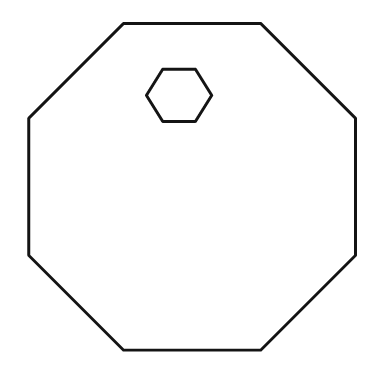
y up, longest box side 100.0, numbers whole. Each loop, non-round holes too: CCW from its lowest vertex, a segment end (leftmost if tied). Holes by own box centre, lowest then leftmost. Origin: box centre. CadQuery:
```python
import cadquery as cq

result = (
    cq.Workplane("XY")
    .moveTo(-21.0, -50.0)
    .lineTo(21.0, -50.0)
    .lineTo(50.0, -21.0)
    .lineTo(50.0, 21.0)
    .lineTo(21.0, 50.0)
    .lineTo(-21.0, 50.0)
    .lineTo(-50.0, 21.0)
    .lineTo(-50.0, -21.0)
    .close()
    .moveTo(-9.0, 20.0)
    .lineTo(1.0, 20.0)
    .lineTo(6.0, 28.0)
    .lineTo(1.0, 36.0)
    .lineTo(-9.0, 36.0)
    .lineTo(-14.0, 28.0)
    .close()
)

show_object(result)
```